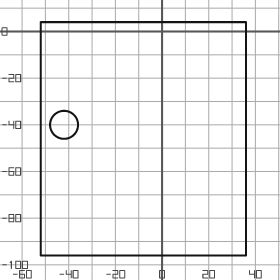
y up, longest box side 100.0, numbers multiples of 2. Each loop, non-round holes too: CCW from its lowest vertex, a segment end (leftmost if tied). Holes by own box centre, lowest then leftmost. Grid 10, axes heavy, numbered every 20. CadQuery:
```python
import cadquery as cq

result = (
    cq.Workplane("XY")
    .moveTo(-52.0, -96.0)
    .lineTo(36.0, -96.0)
    .lineTo(36.0, 4.0)
    .lineTo(-52.0, 4.0)
    .close()
    .moveTo(-42.0, -40.0)
    .circle(6.0)
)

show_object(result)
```